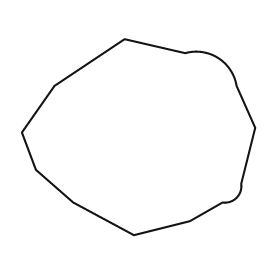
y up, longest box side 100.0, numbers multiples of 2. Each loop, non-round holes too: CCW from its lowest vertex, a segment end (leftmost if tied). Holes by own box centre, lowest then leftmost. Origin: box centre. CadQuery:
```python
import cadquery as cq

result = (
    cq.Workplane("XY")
    .moveTo(-2.0, -42.0)
    .lineTo(22.0, -36.0)
    .lineTo(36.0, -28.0)
    .threePointArc((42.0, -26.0), (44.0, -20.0))
    .lineTo(50.0, 4.0)
    .lineTo(42.0, 22.0)
    .threePointArc((34.0, 34.0), (20.0, 36.0))
    .lineTo(-6.0, 42.0)
    .lineTo(-36.0, 22.0)
    .lineTo(-50.0, 2.0)
    .lineTo(-44.0, -14.0)
    .lineTo(-28.0, -28.0)
    .close()
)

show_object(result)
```